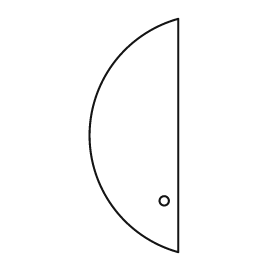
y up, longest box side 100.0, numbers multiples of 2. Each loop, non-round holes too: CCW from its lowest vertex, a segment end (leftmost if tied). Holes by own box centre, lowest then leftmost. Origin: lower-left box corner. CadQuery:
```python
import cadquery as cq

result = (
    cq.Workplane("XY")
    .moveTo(38.0, 0.0)
    .lineTo(38.0, 100.0)
    .threePointArc((0.0, 50.0), (38.0, 0.0))
    .close()
    .moveTo(32.0, 22.0)
    .circle(2.0)
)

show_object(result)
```